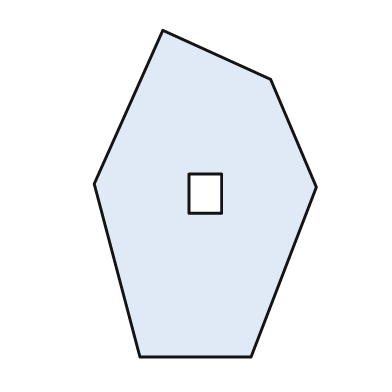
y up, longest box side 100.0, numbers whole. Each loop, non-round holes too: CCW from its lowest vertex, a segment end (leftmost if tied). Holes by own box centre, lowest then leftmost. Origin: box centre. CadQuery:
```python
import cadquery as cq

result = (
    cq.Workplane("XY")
    .moveTo(-20.0, -50.0)
    .lineTo(14.0, -50.0)
    .lineTo(34.0, 2.0)
    .lineTo(20.0, 35.0)
    .lineTo(-13.0, 50.0)
    .lineTo(-34.0, 3.0)
    .close()
    .moveTo(-5.0, -6.0)
    .lineTo(5.0, -6.0)
    .lineTo(5.0, 6.0)
    .lineTo(-5.0, 6.0)
    .close()
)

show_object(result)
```